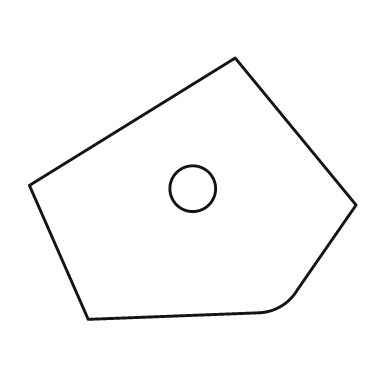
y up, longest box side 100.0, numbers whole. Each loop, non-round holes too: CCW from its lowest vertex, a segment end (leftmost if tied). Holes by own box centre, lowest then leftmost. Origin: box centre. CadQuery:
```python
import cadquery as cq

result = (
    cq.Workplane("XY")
    .moveTo(-32.0, -40.0)
    .lineTo(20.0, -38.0)
    .threePointArc((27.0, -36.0), (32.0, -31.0))
    .lineTo(50.0, -5.0)
    .lineTo(13.0, 40.0)
    .lineTo(-50.0, 1.0)
    .close()
    .moveTo(0.0, 0.0)
    .circle(7.0)
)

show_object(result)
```